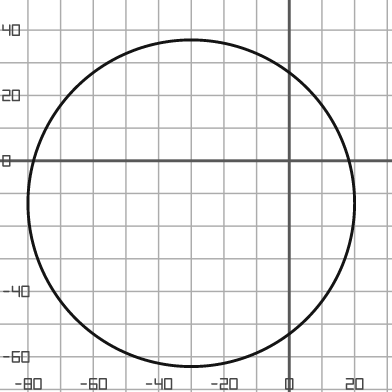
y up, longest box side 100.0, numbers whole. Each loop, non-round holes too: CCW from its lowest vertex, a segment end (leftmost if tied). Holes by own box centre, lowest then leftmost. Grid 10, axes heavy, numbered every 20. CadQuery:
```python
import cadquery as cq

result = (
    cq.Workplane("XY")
    .moveTo(-30.0, -13.0)
    .circle(50.0)
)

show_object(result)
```